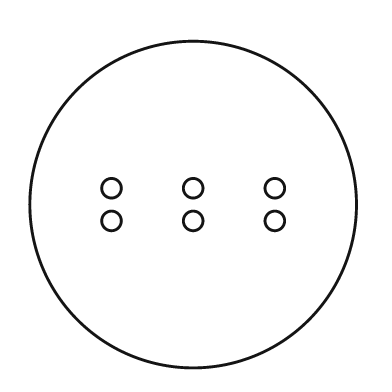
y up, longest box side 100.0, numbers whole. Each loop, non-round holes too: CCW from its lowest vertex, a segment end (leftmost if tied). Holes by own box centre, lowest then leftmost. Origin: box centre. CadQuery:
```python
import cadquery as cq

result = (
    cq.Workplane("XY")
    .moveTo(0.0, 0.0)
    .circle(50.0)
    .moveTo(-25.0, -5.0)
    .circle(3.0)
    .moveTo(0.0, -5.0)
    .circle(3.0)
    .moveTo(25.0, -5.0)
    .circle(3.0)
    .moveTo(-25.0, 5.0)
    .circle(3.0)
    .moveTo(0.0, 5.0)
    .circle(3.0)
    .moveTo(25.0, 5.0)
    .circle(3.0)
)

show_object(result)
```